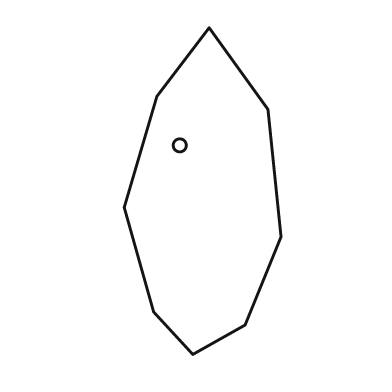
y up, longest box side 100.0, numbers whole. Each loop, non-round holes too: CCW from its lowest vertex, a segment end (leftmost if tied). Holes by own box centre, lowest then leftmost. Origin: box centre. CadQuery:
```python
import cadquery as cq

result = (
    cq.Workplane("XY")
    .moveTo(-3.0, -50.0)
    .lineTo(13.0, -41.0)
    .lineTo(24.0, -14.0)
    .lineTo(20.0, 25.0)
    .lineTo(2.0, 50.0)
    .lineTo(-14.0, 29.0)
    .lineTo(-24.0, -5.0)
    .lineTo(-15.0, -37.0)
    .close()
    .moveTo(-7.0, 14.0)
    .circle(2.0)
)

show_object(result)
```